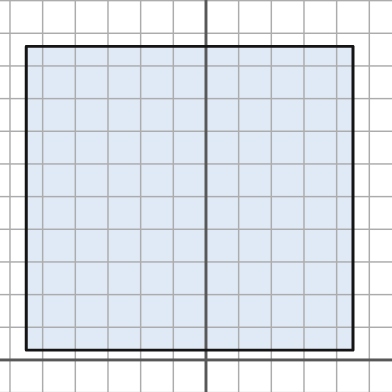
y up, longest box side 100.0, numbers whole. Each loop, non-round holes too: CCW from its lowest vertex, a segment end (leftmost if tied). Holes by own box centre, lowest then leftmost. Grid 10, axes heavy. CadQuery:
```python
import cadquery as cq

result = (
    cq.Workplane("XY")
    .moveTo(-55.0, 3.0)
    .lineTo(45.0, 3.0)
    .lineTo(45.0, 96.0)
    .lineTo(-55.0, 96.0)
    .close()
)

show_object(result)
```